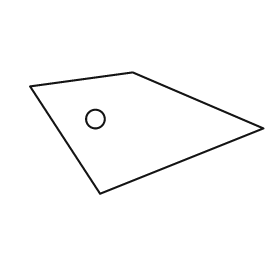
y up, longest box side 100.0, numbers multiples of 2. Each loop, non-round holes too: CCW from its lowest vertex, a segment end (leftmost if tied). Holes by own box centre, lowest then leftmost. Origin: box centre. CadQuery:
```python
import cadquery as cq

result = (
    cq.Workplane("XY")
    .moveTo(-20.0, -26.0)
    .lineTo(50.0, 2.0)
    .lineTo(-6.0, 26.0)
    .lineTo(-50.0, 20.0)
    .close()
    .moveTo(-22.0, 6.0)
    .circle(4.0)
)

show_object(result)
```